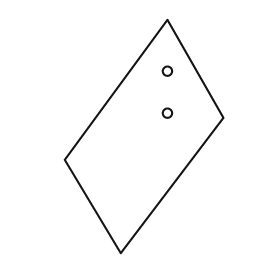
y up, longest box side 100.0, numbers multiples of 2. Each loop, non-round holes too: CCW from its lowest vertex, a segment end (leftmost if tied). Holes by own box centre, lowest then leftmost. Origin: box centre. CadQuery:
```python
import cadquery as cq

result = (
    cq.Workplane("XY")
    .moveTo(-10.0, -50.0)
    .lineTo(34.0, 8.0)
    .lineTo(10.0, 50.0)
    .lineTo(-34.0, -10.0)
    .close()
    .moveTo(10.0, 10.0)
    .circle(2.0)
    .moveTo(10.0, 28.0)
    .circle(2.0)
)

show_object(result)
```